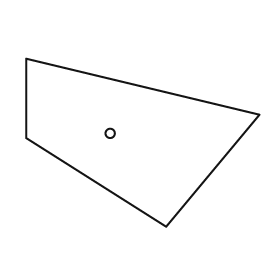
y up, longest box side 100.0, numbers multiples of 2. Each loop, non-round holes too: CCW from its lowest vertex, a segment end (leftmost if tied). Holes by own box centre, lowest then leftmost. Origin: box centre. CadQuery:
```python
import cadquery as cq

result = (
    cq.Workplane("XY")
    .moveTo(10.0, -36.0)
    .lineTo(50.0, 12.0)
    .lineTo(-50.0, 36.0)
    .lineTo(-50.0, 2.0)
    .close()
    .moveTo(-14.0, 4.0)
    .circle(2.0)
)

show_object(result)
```